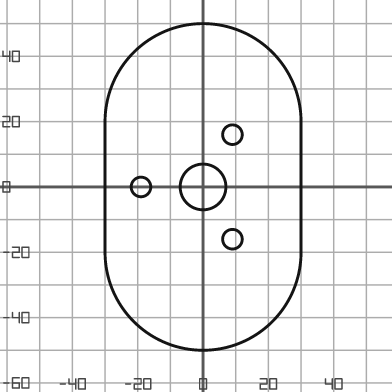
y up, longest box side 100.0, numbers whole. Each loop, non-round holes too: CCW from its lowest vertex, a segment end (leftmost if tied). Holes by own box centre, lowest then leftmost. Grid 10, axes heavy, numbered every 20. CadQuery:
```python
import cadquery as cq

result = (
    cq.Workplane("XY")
    .moveTo(-30.0, -20.0)
    .threePointArc((0.0, -50.0), (30.0, -20.0))
    .lineTo(30.0, 20.0)
    .threePointArc((0.0, 50.0), (-30.0, 20.0))
    .close()
    .moveTo(9.0, -16.0)
    .circle(3.0)
    .moveTo(-19.0, 0.0)
    .circle(3.0)
    .moveTo(0.0, 0.0)
    .circle(7.0)
    .moveTo(9.0, 16.0)
    .circle(3.0)
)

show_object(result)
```